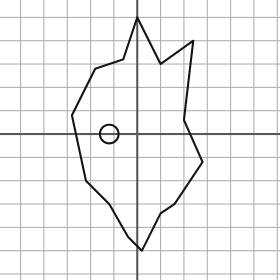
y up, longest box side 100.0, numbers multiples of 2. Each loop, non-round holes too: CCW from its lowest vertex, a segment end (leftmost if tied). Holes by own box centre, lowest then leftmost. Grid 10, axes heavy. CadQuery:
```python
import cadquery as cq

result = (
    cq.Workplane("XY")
    .moveTo(2.0, -50.0)
    .lineTo(10.0, -34.0)
    .lineTo(16.0, -30.0)
    .lineTo(28.0, -12.0)
    .lineTo(20.0, 6.0)
    .lineTo(24.0, 40.0)
    .lineTo(10.0, 30.0)
    .lineTo(0.0, 50.0)
    .lineTo(-6.0, 32.0)
    .lineTo(-18.0, 28.0)
    .lineTo(-28.0, 8.0)
    .lineTo(-22.0, -20.0)
    .lineTo(-12.0, -30.0)
    .lineTo(-4.0, -44.0)
    .close()
    .moveTo(-12.0, 0.0)
    .circle(4.0)
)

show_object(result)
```